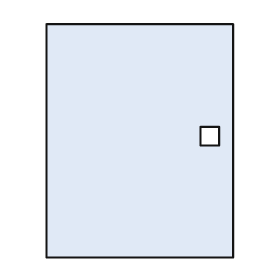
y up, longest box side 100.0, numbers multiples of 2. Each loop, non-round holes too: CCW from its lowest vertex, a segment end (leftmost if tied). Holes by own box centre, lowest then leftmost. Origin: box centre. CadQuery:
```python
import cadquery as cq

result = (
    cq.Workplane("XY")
    .moveTo(-40.0, -50.0)
    .lineTo(40.0, -50.0)
    .lineTo(40.0, 50.0)
    .lineTo(-40.0, 50.0)
    .close()
    .moveTo(26.0, -2.0)
    .lineTo(34.0, -2.0)
    .lineTo(34.0, 6.0)
    .lineTo(26.0, 6.0)
    .close()
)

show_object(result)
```